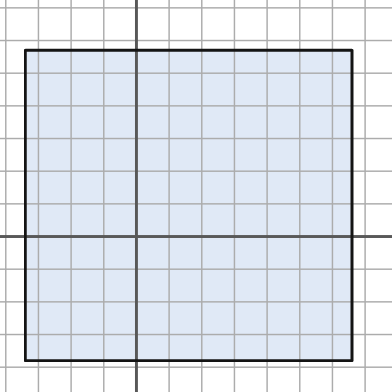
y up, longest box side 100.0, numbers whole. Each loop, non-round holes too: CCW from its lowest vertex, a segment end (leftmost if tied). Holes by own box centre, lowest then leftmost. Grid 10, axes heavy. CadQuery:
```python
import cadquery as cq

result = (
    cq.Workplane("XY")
    .moveTo(-34.0, -38.0)
    .lineTo(66.0, -38.0)
    .lineTo(66.0, 57.0)
    .lineTo(-34.0, 57.0)
    .close()
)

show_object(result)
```